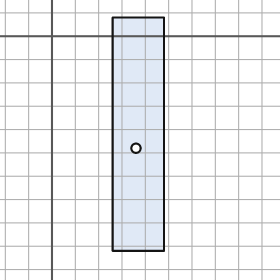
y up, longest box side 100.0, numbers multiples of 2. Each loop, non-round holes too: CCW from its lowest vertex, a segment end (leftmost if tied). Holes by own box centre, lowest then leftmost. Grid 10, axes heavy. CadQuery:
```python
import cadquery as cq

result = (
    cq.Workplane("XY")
    .moveTo(26.0, -92.0)
    .lineTo(48.0, -92.0)
    .lineTo(48.0, 8.0)
    .lineTo(26.0, 8.0)
    .close()
    .moveTo(36.0, -48.0)
    .circle(2.0)
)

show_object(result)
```